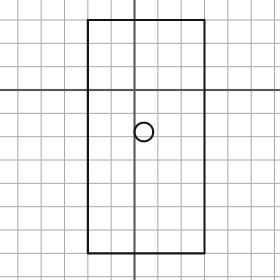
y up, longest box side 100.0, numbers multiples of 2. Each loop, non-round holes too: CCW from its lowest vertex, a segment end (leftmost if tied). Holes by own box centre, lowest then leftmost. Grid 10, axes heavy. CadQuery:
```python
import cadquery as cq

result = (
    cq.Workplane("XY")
    .moveTo(-20.0, -70.0)
    .lineTo(30.0, -70.0)
    .lineTo(30.0, 30.0)
    .lineTo(-20.0, 30.0)
    .close()
    .moveTo(4.0, -18.0)
    .circle(4.0)
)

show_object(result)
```